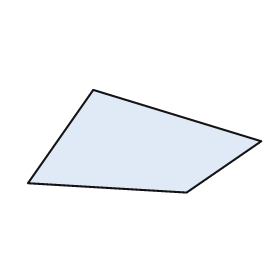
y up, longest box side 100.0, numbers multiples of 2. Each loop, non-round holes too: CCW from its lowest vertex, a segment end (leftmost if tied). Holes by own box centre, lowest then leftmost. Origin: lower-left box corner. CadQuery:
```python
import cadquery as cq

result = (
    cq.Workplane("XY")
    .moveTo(68.0, 0.0)
    .lineTo(100.0, 22.0)
    .lineTo(28.0, 44.0)
    .lineTo(0.0, 4.0)
    .close()
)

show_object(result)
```